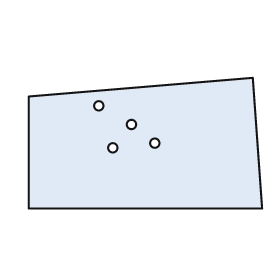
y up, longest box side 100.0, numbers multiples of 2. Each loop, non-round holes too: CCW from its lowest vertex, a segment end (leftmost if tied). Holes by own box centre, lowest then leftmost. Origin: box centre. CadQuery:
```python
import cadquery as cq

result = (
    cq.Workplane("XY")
    .moveTo(-50.0, -28.0)
    .lineTo(50.0, -28.0)
    .lineTo(46.0, 28.0)
    .lineTo(-50.0, 20.0)
    .close()
    .moveTo(-14.0, -2.0)
    .circle(2.0)
    .moveTo(4.0, 0.0)
    .circle(2.0)
    .moveTo(-6.0, 8.0)
    .circle(2.0)
    .moveTo(-20.0, 16.0)
    .circle(2.0)
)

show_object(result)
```